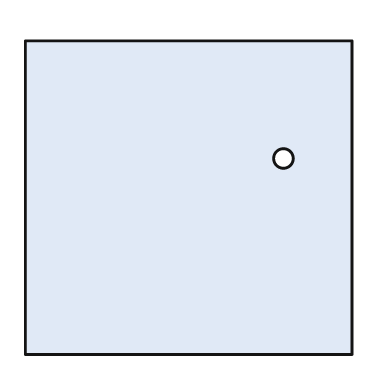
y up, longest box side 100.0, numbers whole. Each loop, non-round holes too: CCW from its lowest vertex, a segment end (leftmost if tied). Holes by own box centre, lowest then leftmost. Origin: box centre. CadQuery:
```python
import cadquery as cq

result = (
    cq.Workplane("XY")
    .moveTo(-50.0, -48.0)
    .lineTo(50.0, -48.0)
    .lineTo(50.0, 48.0)
    .lineTo(-50.0, 48.0)
    .close()
    .moveTo(29.0, 12.0)
    .circle(3.0)
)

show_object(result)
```